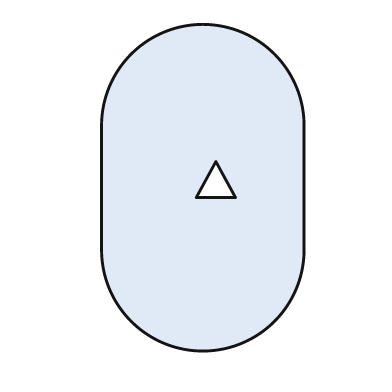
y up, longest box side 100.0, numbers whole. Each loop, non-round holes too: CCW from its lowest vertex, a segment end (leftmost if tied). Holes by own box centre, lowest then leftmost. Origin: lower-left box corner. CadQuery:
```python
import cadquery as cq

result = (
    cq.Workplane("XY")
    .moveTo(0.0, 31.0)
    .threePointArc((31.0, 0.0), (62.0, 31.0))
    .lineTo(62.0, 69.0)
    .threePointArc((31.0, 100.0), (0.0, 69.0))
    .close()
    .moveTo(29.0, 47.0)
    .lineTo(41.0, 47.0)
    .lineTo(35.0, 58.0)
    .close()
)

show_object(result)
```